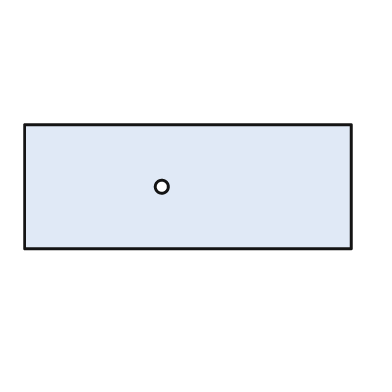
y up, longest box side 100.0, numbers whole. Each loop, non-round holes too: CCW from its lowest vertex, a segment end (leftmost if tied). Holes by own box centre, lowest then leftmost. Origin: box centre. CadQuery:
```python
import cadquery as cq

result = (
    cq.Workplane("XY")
    .moveTo(-50.0, -19.0)
    .lineTo(50.0, -19.0)
    .lineTo(50.0, 19.0)
    .lineTo(-50.0, 19.0)
    .close()
    .moveTo(-8.0, 0.0)
    .circle(2.0)
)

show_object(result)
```